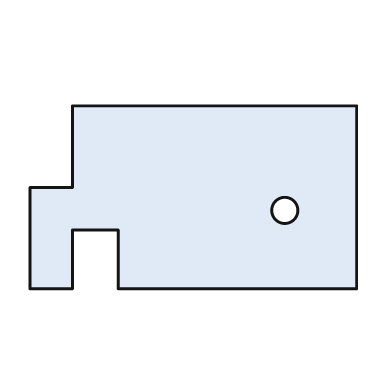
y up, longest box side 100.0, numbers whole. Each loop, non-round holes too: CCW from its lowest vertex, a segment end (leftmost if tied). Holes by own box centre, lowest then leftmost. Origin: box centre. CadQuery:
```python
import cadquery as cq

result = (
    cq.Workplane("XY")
    .moveTo(-50.0, -28.0)
    .lineTo(-37.0, -28.0)
    .lineTo(-37.0, -10.0)
    .lineTo(-23.0, -10.0)
    .lineTo(-23.0, -28.0)
    .lineTo(50.0, -28.0)
    .lineTo(50.0, 28.0)
    .lineTo(-37.0, 28.0)
    .lineTo(-37.0, 3.0)
    .lineTo(-50.0, 3.0)
    .close()
    .moveTo(28.0, -4.0)
    .circle(4.0)
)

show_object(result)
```